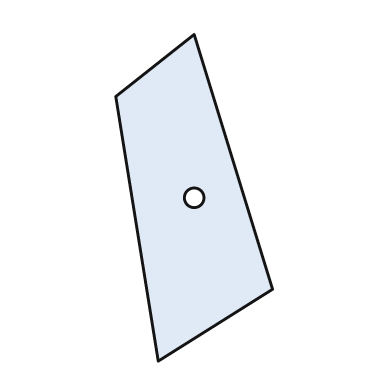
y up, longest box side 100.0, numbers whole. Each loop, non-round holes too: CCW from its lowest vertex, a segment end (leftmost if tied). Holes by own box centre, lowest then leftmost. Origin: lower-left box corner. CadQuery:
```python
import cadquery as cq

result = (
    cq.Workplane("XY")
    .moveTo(13.0, 0.0)
    .lineTo(48.0, 22.0)
    .lineTo(24.0, 100.0)
    .lineTo(0.0, 81.0)
    .close()
    .moveTo(24.0, 50.0)
    .circle(3.0)
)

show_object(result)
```